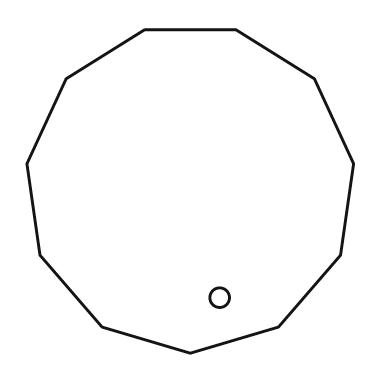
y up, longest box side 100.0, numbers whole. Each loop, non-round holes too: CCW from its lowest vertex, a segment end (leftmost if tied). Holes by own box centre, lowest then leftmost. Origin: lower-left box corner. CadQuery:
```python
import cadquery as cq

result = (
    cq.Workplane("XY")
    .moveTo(50.0, 0.0)
    .lineTo(77.0, 8.0)
    .lineTo(96.0, 30.0)
    .lineTo(100.0, 58.0)
    .lineTo(88.0, 84.0)
    .lineTo(64.0, 99.0)
    .lineTo(36.0, 99.0)
    .lineTo(12.0, 84.0)
    .lineTo(0.0, 58.0)
    .lineTo(4.0, 30.0)
    .lineTo(23.0, 8.0)
    .close()
    .moveTo(59.0, 17.0)
    .circle(3.0)
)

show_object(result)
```